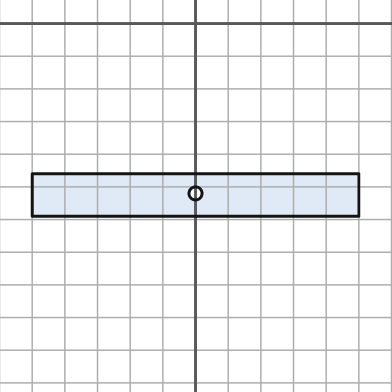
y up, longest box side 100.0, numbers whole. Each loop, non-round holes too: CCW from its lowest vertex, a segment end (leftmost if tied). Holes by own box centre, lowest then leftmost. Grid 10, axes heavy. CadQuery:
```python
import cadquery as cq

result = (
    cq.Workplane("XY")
    .moveTo(-50.0, -59.0)
    .lineTo(50.0, -59.0)
    .lineTo(50.0, -46.0)
    .lineTo(-50.0, -46.0)
    .close()
    .moveTo(0.0, -52.0)
    .circle(2.0)
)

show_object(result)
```